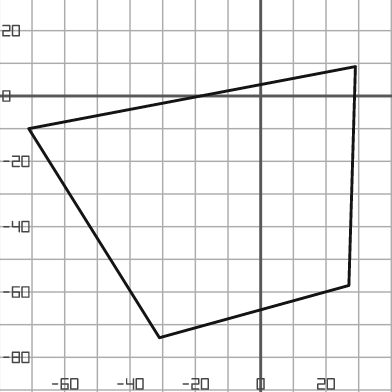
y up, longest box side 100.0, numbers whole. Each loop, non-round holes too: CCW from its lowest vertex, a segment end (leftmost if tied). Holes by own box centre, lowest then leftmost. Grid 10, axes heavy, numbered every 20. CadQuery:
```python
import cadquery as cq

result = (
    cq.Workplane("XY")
    .moveTo(-31.0, -74.0)
    .lineTo(27.0, -58.0)
    .lineTo(29.0, 9.0)
    .lineTo(-71.0, -10.0)
    .close()
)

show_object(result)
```